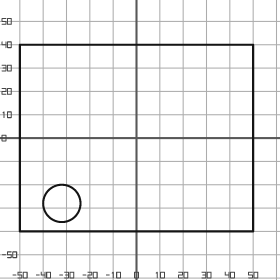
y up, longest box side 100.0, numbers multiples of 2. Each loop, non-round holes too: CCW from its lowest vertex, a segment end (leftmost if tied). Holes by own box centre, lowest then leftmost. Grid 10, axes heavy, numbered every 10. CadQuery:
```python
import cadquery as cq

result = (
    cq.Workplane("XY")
    .moveTo(-50.0, -40.0)
    .lineTo(50.0, -40.0)
    .lineTo(50.0, 40.0)
    .lineTo(-50.0, 40.0)
    .close()
    .moveTo(-32.0, -28.0)
    .circle(8.0)
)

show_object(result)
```